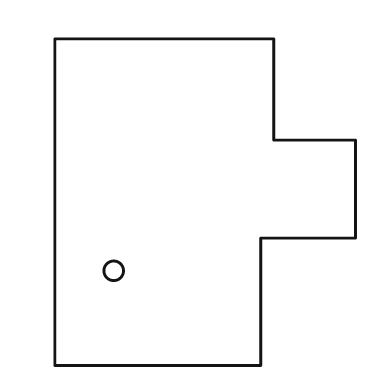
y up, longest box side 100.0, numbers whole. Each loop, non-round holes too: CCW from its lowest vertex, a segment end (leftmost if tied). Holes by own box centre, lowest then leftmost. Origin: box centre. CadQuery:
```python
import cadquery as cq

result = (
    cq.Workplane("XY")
    .moveTo(-46.0, -50.0)
    .lineTo(17.0, -50.0)
    .lineTo(17.0, -11.0)
    .lineTo(46.0, -11.0)
    .lineTo(46.0, 19.0)
    .lineTo(21.0, 19.0)
    .lineTo(21.0, 50.0)
    .lineTo(-46.0, 50.0)
    .close()
    .moveTo(-28.0, -21.0)
    .circle(3.0)
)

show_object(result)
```